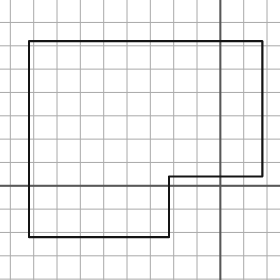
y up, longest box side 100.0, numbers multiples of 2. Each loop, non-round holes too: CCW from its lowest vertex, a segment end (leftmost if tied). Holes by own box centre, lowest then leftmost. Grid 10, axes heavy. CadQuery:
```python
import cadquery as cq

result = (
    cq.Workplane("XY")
    .moveTo(-82.0, -22.0)
    .lineTo(-22.0, -22.0)
    .lineTo(-22.0, 4.0)
    .lineTo(18.0, 4.0)
    .lineTo(18.0, 62.0)
    .lineTo(-82.0, 62.0)
    .close()
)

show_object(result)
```